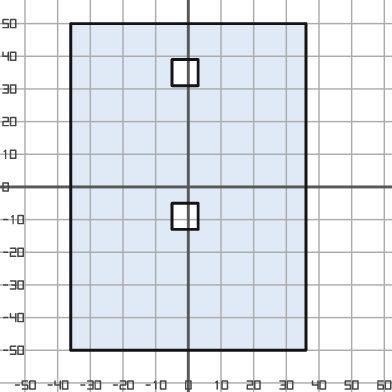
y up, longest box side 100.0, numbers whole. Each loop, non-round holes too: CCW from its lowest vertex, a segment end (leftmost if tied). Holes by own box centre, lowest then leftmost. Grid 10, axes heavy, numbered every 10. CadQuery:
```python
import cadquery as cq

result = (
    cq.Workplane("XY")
    .moveTo(-36.0, -50.0)
    .lineTo(36.0, -50.0)
    .lineTo(36.0, 50.0)
    .lineTo(-36.0, 50.0)
    .close()
    .moveTo(-5.0, -13.0)
    .lineTo(3.0, -13.0)
    .lineTo(3.0, -5.0)
    .lineTo(-5.0, -5.0)
    .close()
    .moveTo(-5.0, 31.0)
    .lineTo(3.0, 31.0)
    .lineTo(3.0, 39.0)
    .lineTo(-5.0, 39.0)
    .close()
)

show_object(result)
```